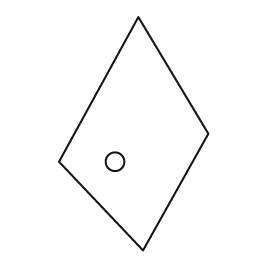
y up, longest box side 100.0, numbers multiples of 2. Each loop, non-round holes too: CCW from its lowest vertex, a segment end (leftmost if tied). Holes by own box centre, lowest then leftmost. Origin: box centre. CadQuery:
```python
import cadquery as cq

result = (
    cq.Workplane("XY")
    .moveTo(4.0, -50.0)
    .lineTo(32.0, 0.0)
    .lineTo(2.0, 50.0)
    .lineTo(-32.0, -12.0)
    .close()
    .moveTo(-8.0, -12.0)
    .circle(4.0)
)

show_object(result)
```